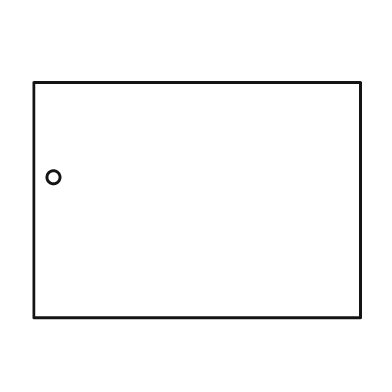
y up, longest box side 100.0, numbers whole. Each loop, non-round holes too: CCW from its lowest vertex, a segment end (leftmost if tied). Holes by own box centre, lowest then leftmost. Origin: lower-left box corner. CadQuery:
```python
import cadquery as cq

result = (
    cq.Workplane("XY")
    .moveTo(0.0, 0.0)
    .lineTo(100.0, 0.0)
    .lineTo(100.0, 72.0)
    .lineTo(0.0, 72.0)
    .close()
    .moveTo(6.0, 43.0)
    .circle(2.0)
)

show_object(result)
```